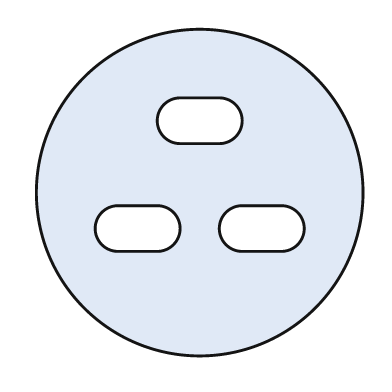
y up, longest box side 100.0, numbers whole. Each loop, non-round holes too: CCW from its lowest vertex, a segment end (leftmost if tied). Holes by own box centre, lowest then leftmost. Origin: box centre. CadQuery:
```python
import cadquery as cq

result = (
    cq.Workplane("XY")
    .moveTo(0.0, 0.0)
    .circle(50.0)
    .moveTo(-25.0, -18.0)
    .lineTo(-13.0, -18.0)
    .threePointArc((-6.0, -11.0), (-13.0, -4.0))
    .lineTo(-25.0, -4.0)
    .threePointArc((-32.0, -11.0), (-25.0, -18.0))
    .close()
    .moveTo(13.0, -18.0)
    .lineTo(25.0, -18.0)
    .threePointArc((32.0, -11.0), (25.0, -4.0))
    .lineTo(13.0, -4.0)
    .threePointArc((6.0, -11.0), (13.0, -18.0))
    .close()
    .moveTo(-6.0, 15.0)
    .lineTo(6.0, 15.0)
    .threePointArc((13.0, 22.0), (6.0, 29.0))
    .lineTo(-6.0, 29.0)
    .threePointArc((-13.0, 22.0), (-6.0, 15.0))
    .close()
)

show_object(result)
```